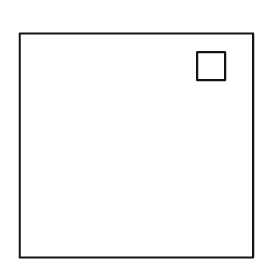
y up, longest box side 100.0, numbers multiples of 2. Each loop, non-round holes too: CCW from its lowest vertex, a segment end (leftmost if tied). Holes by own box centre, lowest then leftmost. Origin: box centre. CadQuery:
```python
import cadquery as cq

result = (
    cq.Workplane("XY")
    .moveTo(-50.0, -48.0)
    .lineTo(50.0, -48.0)
    .lineTo(50.0, 48.0)
    .lineTo(-50.0, 48.0)
    .close()
    .moveTo(26.0, 28.0)
    .lineTo(38.0, 28.0)
    .lineTo(38.0, 40.0)
    .lineTo(26.0, 40.0)
    .close()
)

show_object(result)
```